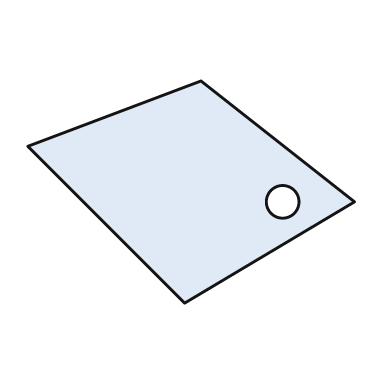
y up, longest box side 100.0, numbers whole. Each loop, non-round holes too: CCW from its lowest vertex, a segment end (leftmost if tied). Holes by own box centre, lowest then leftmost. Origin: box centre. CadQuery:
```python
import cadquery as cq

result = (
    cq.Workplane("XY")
    .moveTo(-2.0, -34.0)
    .lineTo(50.0, -3.0)
    .lineTo(3.0, 34.0)
    .lineTo(-50.0, 14.0)
    .close()
    .moveTo(28.0, -3.0)
    .circle(5.0)
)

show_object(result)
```